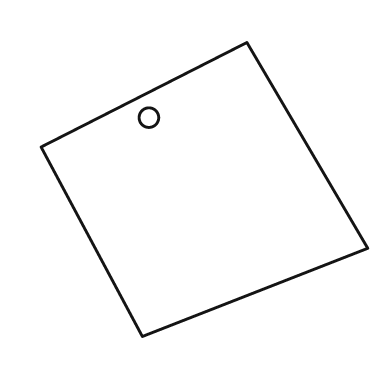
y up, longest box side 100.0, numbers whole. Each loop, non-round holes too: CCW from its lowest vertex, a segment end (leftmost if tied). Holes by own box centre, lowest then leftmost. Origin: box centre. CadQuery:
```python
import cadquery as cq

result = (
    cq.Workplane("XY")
    .moveTo(-19.0, -45.0)
    .lineTo(50.0, -18.0)
    .lineTo(13.0, 45.0)
    .lineTo(-50.0, 13.0)
    .close()
    .moveTo(-17.0, 22.0)
    .circle(3.0)
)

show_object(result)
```